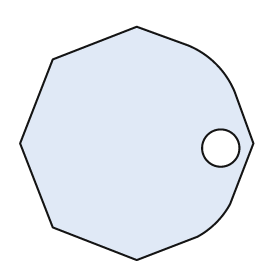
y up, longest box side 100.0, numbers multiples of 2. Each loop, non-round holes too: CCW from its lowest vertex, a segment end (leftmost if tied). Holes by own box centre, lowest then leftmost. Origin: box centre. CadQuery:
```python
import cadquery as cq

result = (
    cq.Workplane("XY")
    .moveTo(0.0, -50.0)
    .lineTo(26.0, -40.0)
    .threePointArc((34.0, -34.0), (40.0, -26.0))
    .lineTo(50.0, 0.0)
    .lineTo(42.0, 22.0)
    .threePointArc((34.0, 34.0), (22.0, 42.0))
    .lineTo(0.0, 50.0)
    .lineTo(-36.0, 36.0)
    .lineTo(-50.0, 0.0)
    .lineTo(-36.0, -36.0)
    .close()
    .moveTo(36.0, -2.0)
    .circle(8.0)
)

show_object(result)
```